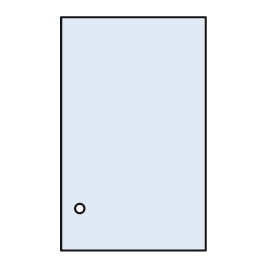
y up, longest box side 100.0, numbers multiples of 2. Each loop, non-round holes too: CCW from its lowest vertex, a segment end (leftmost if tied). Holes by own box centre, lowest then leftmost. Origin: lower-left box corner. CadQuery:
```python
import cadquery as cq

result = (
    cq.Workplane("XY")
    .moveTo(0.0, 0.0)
    .lineTo(62.0, 0.0)
    .lineTo(62.0, 100.0)
    .lineTo(0.0, 100.0)
    .close()
    .moveTo(8.0, 18.0)
    .circle(2.0)
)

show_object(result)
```